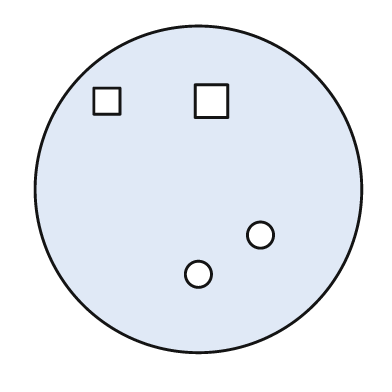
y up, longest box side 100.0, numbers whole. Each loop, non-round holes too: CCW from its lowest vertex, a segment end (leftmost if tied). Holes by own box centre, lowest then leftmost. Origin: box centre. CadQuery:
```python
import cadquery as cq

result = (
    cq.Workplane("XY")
    .moveTo(0.0, 0.0)
    .circle(50.0)
    .moveTo(0.0, -26.0)
    .circle(4.0)
    .moveTo(19.0, -14.0)
    .circle(4.0)
    .moveTo(-32.0, 23.0)
    .lineTo(-24.0, 23.0)
    .lineTo(-24.0, 31.0)
    .lineTo(-32.0, 31.0)
    .close()
    .moveTo(-1.0, 22.0)
    .lineTo(9.0, 22.0)
    .lineTo(9.0, 32.0)
    .lineTo(-1.0, 32.0)
    .close()
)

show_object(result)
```